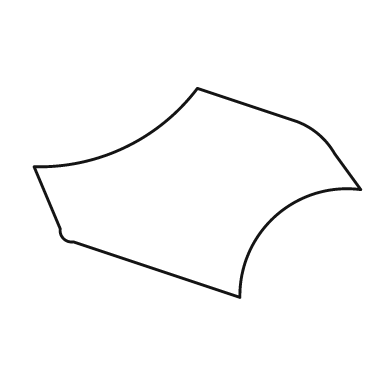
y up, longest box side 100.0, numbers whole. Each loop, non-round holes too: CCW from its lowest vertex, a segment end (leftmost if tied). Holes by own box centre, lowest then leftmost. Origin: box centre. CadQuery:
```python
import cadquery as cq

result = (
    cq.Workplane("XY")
    .moveTo(13.0, -32.0)
    .threePointArc((24.0, -7.0), (50.0, 1.0))
    .lineTo(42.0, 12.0)
    .threePointArc((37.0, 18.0), (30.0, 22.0))
    .lineTo(0.0, 32.0)
    .threePointArc((-22.0, 14.0), (-50.0, 8.0))
    .lineTo(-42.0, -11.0)
    .threePointArc((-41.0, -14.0), (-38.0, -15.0))
    .close()
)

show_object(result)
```